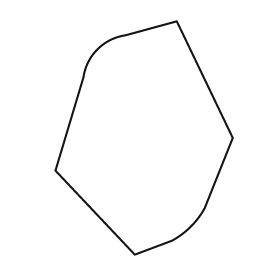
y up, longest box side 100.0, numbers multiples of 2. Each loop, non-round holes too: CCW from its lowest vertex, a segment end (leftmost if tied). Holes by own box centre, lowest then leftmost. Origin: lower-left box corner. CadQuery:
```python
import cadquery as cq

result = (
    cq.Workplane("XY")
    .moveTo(34.0, 0.0)
    .lineTo(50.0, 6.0)
    .threePointArc((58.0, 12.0), (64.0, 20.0))
    .lineTo(76.0, 50.0)
    .lineTo(52.0, 100.0)
    .lineTo(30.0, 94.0)
    .threePointArc((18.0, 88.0), (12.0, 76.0))
    .lineTo(0.0, 36.0)
    .close()
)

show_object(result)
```